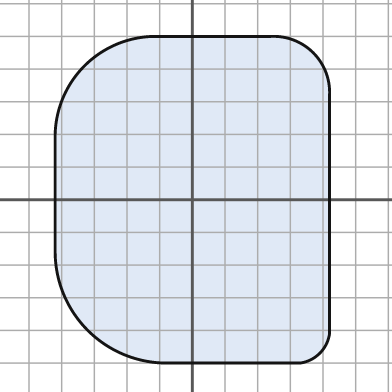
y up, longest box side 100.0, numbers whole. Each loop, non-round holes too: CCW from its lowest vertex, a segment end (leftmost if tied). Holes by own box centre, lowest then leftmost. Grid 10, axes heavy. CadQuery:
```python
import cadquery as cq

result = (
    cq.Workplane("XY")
    .moveTo(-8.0, -50.0)
    .lineTo(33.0, -50.0)
    .threePointArc((39.0, -47.0), (42.0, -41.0))
    .lineTo(42.0, 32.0)
    .threePointArc((37.0, 45.0), (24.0, 50.0))
    .lineTo(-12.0, 50.0)
    .threePointArc((-33.0, 41.0), (-42.0, 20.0))
    .lineTo(-42.0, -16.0)
    .threePointArc((-32.0, -40.0), (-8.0, -50.0))
    .close()
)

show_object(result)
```